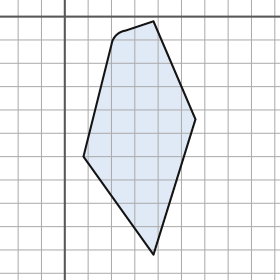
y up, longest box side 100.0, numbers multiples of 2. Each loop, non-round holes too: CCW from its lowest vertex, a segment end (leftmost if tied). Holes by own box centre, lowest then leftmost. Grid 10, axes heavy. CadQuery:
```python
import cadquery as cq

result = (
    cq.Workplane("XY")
    .moveTo(38.0, -102.0)
    .lineTo(56.0, -44.0)
    .lineTo(38.0, -2.0)
    .lineTo(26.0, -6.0)
    .threePointArc((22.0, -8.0), (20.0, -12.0))
    .lineTo(8.0, -60.0)
    .close()
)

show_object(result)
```